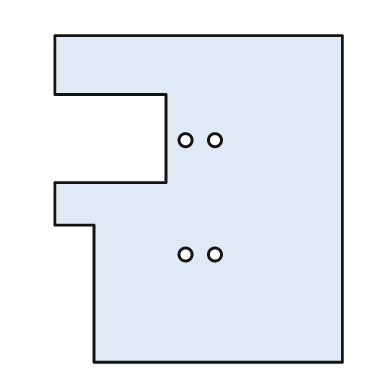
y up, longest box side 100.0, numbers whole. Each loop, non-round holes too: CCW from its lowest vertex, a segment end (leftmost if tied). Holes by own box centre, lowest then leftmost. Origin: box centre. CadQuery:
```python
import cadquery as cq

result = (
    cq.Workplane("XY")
    .moveTo(-32.0, -50.0)
    .lineTo(44.0, -50.0)
    .lineTo(44.0, 50.0)
    .lineTo(-44.0, 50.0)
    .lineTo(-44.0, 32.0)
    .lineTo(-10.0, 32.0)
    .lineTo(-10.0, 5.0)
    .lineTo(-44.0, 5.0)
    .lineTo(-44.0, -8.0)
    .lineTo(-32.0, -8.0)
    .close()
    .moveTo(-4.0, -17.0)
    .circle(2.0)
    .moveTo(5.0, -17.0)
    .circle(2.0)
    .moveTo(-4.0, 18.0)
    .circle(2.0)
    .moveTo(5.0, 18.0)
    .circle(2.0)
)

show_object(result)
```